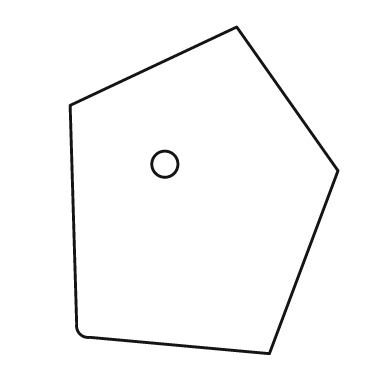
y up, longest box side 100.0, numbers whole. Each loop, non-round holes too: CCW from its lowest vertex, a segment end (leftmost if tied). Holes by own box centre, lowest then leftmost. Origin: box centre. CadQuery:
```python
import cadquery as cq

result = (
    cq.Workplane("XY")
    .moveTo(20.0, -50.0)
    .lineTo(41.0, 6.0)
    .lineTo(10.0, 50.0)
    .lineTo(-41.0, 26.0)
    .lineTo(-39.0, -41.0)
    .threePointArc((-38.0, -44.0), (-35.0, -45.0))
    .close()
    .moveTo(-12.0, 8.0)
    .circle(4.0)
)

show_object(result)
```